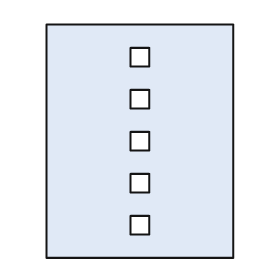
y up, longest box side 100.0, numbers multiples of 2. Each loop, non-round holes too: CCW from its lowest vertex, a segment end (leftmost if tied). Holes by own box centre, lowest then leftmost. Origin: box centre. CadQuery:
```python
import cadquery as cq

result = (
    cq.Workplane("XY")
    .moveTo(-40.0, -50.0)
    .lineTo(40.0, -50.0)
    .lineTo(40.0, 50.0)
    .lineTo(-40.0, 50.0)
    .close()
    .moveTo(-4.0, -40.0)
    .lineTo(4.0, -40.0)
    .lineTo(4.0, -32.0)
    .lineTo(-4.0, -32.0)
    .close()
    .moveTo(-4.0, -22.0)
    .lineTo(4.0, -22.0)
    .lineTo(4.0, -14.0)
    .lineTo(-4.0, -14.0)
    .close()
    .moveTo(-4.0, -4.0)
    .lineTo(4.0, -4.0)
    .lineTo(4.0, 4.0)
    .lineTo(-4.0, 4.0)
    .close()
    .moveTo(-4.0, 14.0)
    .lineTo(4.0, 14.0)
    .lineTo(4.0, 22.0)
    .lineTo(-4.0, 22.0)
    .close()
    .moveTo(-4.0, 32.0)
    .lineTo(4.0, 32.0)
    .lineTo(4.0, 40.0)
    .lineTo(-4.0, 40.0)
    .close()
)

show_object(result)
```